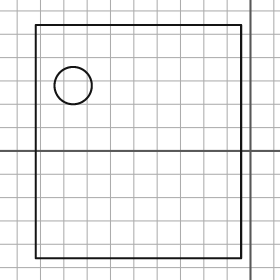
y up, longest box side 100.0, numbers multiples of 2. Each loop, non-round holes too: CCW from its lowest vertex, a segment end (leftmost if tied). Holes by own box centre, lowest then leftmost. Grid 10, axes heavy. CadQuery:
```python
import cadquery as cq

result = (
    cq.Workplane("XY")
    .moveTo(-92.0, -46.0)
    .lineTo(-4.0, -46.0)
    .lineTo(-4.0, 54.0)
    .lineTo(-92.0, 54.0)
    .close()
    .moveTo(-76.0, 28.0)
    .circle(8.0)
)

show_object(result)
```